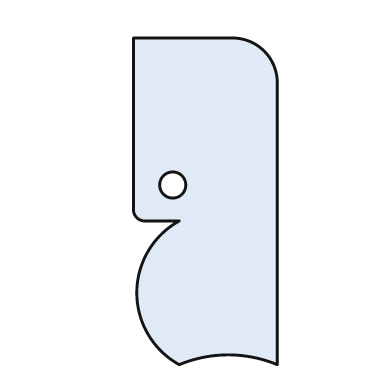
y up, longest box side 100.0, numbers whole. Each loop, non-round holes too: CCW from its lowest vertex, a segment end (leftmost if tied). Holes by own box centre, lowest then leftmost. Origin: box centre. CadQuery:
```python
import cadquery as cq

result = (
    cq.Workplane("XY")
    .moveTo(-8.0, -50.0)
    .threePointArc((7.0, -47.0), (22.0, -50.0))
    .lineTo(22.0, 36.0)
    .threePointArc((18.0, 46.0), (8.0, 50.0))
    .lineTo(-22.0, 50.0)
    .lineTo(-22.0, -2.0)
    .threePointArc((-21.0, -5.0), (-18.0, -6.0))
    .lineTo(-8.0, -6.0)
    .threePointArc((-21.0, -28.0), (-8.0, -50.0))
    .close()
    .moveTo(-10.0, 5.0)
    .circle(4.0)
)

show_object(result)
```